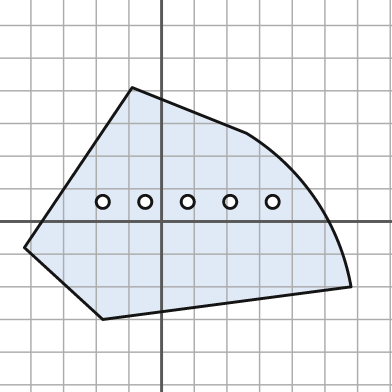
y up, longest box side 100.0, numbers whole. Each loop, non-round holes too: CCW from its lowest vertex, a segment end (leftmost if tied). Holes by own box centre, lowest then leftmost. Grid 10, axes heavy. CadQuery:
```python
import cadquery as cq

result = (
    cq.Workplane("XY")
    .moveTo(-18.0, -30.0)
    .lineTo(58.0, -20.0)
    .threePointArc((47.0, 7.0), (26.0, 27.0))
    .lineTo(-9.0, 41.0)
    .lineTo(-42.0, -8.0)
    .close()
    .moveTo(-18.0, 6.0)
    .circle(2.0)
    .moveTo(-5.0, 6.0)
    .circle(2.0)
    .moveTo(8.0, 6.0)
    .circle(2.0)
    .moveTo(21.0, 6.0)
    .circle(2.0)
    .moveTo(34.0, 6.0)
    .circle(2.0)
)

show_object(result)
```